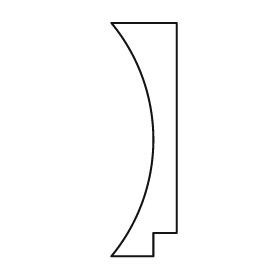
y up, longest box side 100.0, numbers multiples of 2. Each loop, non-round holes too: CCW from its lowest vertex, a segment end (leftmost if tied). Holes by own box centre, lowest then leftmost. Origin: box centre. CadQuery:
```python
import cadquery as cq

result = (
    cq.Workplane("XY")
    .moveTo(-14.0, -50.0)
    .lineTo(4.0, -50.0)
    .lineTo(4.0, -40.0)
    .lineTo(14.0, -40.0)
    .lineTo(14.0, 50.0)
    .lineTo(-14.0, 50.0)
    .threePointArc((4.0, 0.0), (-14.0, -50.0))
    .close()
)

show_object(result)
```